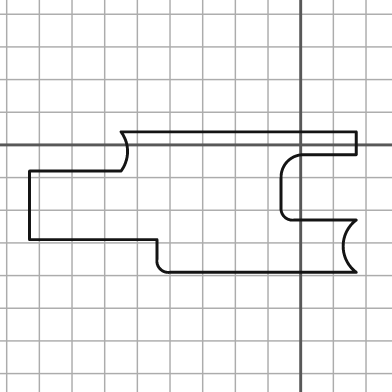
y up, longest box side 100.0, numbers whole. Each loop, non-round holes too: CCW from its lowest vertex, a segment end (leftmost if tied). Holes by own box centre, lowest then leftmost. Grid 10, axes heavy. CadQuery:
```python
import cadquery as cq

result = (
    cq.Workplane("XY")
    .moveTo(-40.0, -39.0)
    .lineTo(17.0, -39.0)
    .threePointArc((13.0, -31.0), (17.0, -23.0))
    .lineTo(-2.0, -23.0)
    .threePointArc((-5.0, -22.0), (-6.0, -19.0))
    .lineTo(-6.0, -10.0)
    .threePointArc((-4.0, -5.0), (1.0, -3.0))
    .lineTo(17.0, -3.0)
    .lineTo(17.0, 4.0)
    .lineTo(-55.0, 4.0)
    .threePointArc((-53.0, -2.0), (-55.0, -8.0))
    .lineTo(-83.0, -8.0)
    .lineTo(-83.0, -29.0)
    .lineTo(-44.0, -29.0)
    .lineTo(-44.0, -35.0)
    .threePointArc((-43.0, -38.0), (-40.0, -39.0))
    .close()
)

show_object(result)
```